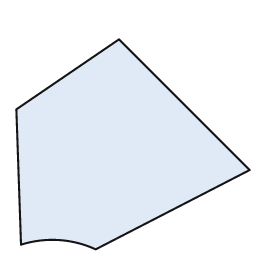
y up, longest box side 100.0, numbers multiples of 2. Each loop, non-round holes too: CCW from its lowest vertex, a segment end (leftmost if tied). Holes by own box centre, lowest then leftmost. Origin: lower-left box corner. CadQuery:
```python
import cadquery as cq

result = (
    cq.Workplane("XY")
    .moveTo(34.0, 0.0)
    .lineTo(100.0, 34.0)
    .lineTo(44.0, 90.0)
    .lineTo(0.0, 60.0)
    .lineTo(2.0, 2.0)
    .threePointArc((18.0, 4.0), (34.0, 0.0))
    .close()
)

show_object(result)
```